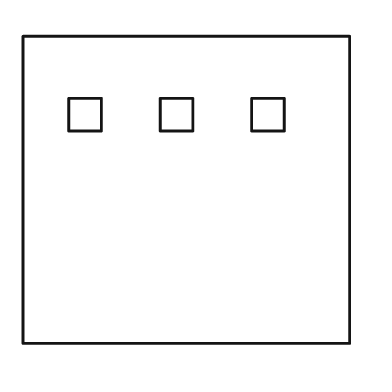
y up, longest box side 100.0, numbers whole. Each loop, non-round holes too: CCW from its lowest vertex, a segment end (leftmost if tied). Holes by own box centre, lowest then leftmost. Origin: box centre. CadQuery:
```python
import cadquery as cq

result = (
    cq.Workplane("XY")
    .moveTo(-50.0, -47.0)
    .lineTo(50.0, -47.0)
    .lineTo(50.0, 47.0)
    .lineTo(-50.0, 47.0)
    .close()
    .moveTo(-36.0, 18.0)
    .lineTo(-26.0, 18.0)
    .lineTo(-26.0, 28.0)
    .lineTo(-36.0, 28.0)
    .close()
    .moveTo(-8.0, 18.0)
    .lineTo(2.0, 18.0)
    .lineTo(2.0, 28.0)
    .lineTo(-8.0, 28.0)
    .close()
    .moveTo(20.0, 18.0)
    .lineTo(30.0, 18.0)
    .lineTo(30.0, 28.0)
    .lineTo(20.0, 28.0)
    .close()
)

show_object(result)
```